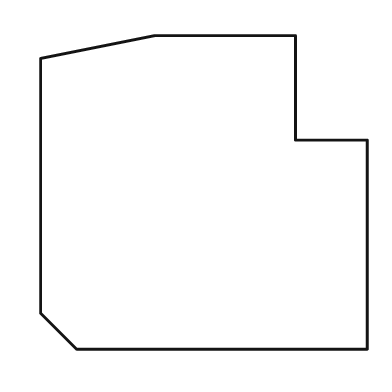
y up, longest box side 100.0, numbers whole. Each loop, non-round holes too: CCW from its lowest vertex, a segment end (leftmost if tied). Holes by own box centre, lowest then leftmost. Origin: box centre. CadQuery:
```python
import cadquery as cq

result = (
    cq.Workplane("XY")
    .moveTo(-39.0, -48.0)
    .lineTo(50.0, -48.0)
    .lineTo(50.0, 16.0)
    .lineTo(28.0, 16.0)
    .lineTo(28.0, 48.0)
    .lineTo(-15.0, 48.0)
    .lineTo(-50.0, 41.0)
    .lineTo(-50.0, -37.0)
    .close()
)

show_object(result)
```